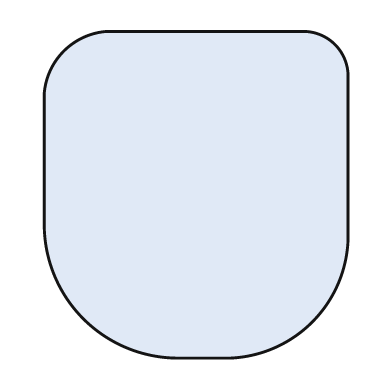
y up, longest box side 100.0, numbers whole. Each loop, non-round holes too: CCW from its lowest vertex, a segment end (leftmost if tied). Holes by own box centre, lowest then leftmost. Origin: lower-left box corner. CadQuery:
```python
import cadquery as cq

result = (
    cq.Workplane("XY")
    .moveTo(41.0, 0.0)
    .lineTo(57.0, 0.0)
    .threePointArc((82.0, 11.0), (93.0, 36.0))
    .lineTo(93.0, 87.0)
    .threePointArc((89.0, 96.0), (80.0, 100.0))
    .lineTo(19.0, 100.0)
    .threePointArc((6.0, 94.0), (0.0, 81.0))
    .lineTo(0.0, 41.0)
    .threePointArc((12.0, 12.0), (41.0, 0.0))
    .close()
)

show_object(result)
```